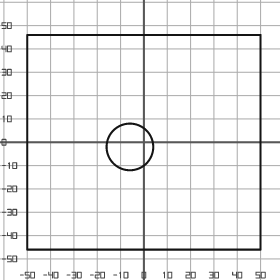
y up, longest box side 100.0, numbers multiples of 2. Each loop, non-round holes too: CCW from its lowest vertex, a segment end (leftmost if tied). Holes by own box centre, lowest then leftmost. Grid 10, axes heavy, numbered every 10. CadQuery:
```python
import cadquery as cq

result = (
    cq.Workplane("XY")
    .moveTo(-50.0, -46.0)
    .lineTo(50.0, -46.0)
    .lineTo(50.0, 46.0)
    .lineTo(-50.0, 46.0)
    .close()
    .moveTo(-6.0, -2.0)
    .circle(10.0)
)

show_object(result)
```